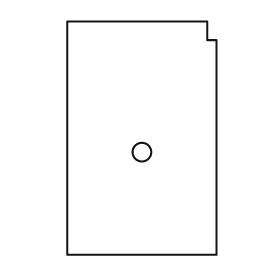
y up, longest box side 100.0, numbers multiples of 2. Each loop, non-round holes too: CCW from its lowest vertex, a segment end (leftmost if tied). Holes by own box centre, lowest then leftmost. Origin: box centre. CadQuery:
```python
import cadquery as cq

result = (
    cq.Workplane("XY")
    .moveTo(-32.0, -50.0)
    .lineTo(32.0, -50.0)
    .lineTo(32.0, 42.0)
    .lineTo(28.0, 42.0)
    .lineTo(28.0, 50.0)
    .lineTo(-32.0, 50.0)
    .close()
    .moveTo(0.0, -6.0)
    .circle(4.0)
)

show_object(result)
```